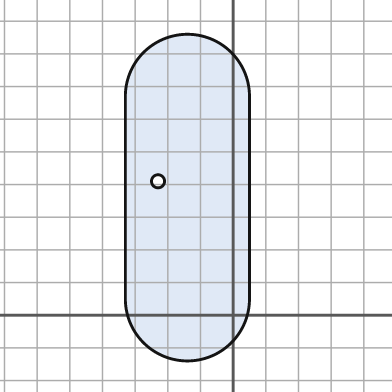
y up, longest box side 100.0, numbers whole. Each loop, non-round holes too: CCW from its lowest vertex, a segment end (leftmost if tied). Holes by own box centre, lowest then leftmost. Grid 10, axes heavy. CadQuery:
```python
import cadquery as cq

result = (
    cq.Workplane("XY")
    .moveTo(-33.0, 5.0)
    .threePointArc((-14.0, -14.0), (5.0, 5.0))
    .lineTo(5.0, 67.0)
    .threePointArc((-14.0, 86.0), (-33.0, 67.0))
    .close()
    .moveTo(-23.0, 41.0)
    .circle(2.0)
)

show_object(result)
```